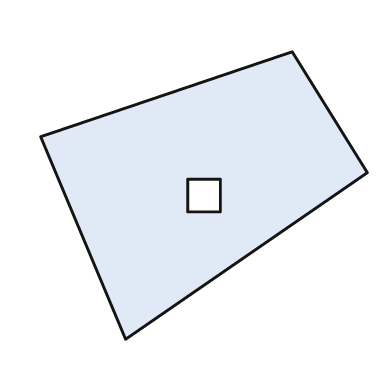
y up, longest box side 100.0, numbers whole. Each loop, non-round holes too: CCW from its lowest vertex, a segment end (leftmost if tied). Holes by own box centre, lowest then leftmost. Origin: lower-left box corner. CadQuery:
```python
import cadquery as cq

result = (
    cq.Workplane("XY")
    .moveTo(26.0, 0.0)
    .lineTo(100.0, 51.0)
    .lineTo(77.0, 88.0)
    .lineTo(0.0, 62.0)
    .close()
    .moveTo(45.0, 39.0)
    .lineTo(55.0, 39.0)
    .lineTo(55.0, 49.0)
    .lineTo(45.0, 49.0)
    .close()
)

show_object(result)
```